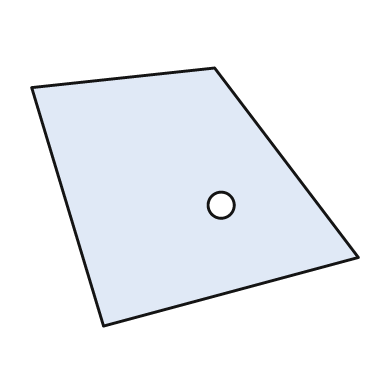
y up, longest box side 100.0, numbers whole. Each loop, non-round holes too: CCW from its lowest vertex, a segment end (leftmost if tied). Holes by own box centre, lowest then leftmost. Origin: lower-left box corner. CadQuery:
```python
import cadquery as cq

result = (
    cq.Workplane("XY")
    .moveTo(22.0, 0.0)
    .lineTo(100.0, 21.0)
    .lineTo(56.0, 79.0)
    .lineTo(0.0, 73.0)
    .close()
    .moveTo(58.0, 37.0)
    .circle(4.0)
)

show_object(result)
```